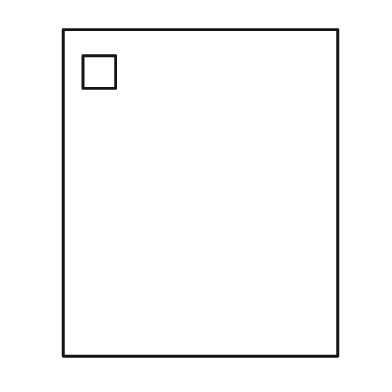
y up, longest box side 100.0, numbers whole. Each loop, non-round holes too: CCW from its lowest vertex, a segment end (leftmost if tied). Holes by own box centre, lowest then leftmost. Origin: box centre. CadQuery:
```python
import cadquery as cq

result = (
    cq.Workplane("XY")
    .moveTo(-42.0, -50.0)
    .lineTo(42.0, -50.0)
    .lineTo(42.0, 50.0)
    .lineTo(-42.0, 50.0)
    .close()
    .moveTo(-36.0, 32.0)
    .lineTo(-26.0, 32.0)
    .lineTo(-26.0, 42.0)
    .lineTo(-36.0, 42.0)
    .close()
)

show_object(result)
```